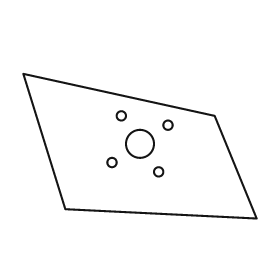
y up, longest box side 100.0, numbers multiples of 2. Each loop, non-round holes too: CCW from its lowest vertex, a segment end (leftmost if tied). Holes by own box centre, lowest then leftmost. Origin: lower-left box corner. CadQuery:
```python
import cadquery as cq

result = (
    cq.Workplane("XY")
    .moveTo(100.0, 0.0)
    .lineTo(82.0, 44.0)
    .lineTo(0.0, 62.0)
    .lineTo(18.0, 4.0)
    .close()
    .moveTo(58.0, 20.0)
    .circle(2.0)
    .moveTo(38.0, 24.0)
    .circle(2.0)
    .moveTo(50.0, 32.0)
    .circle(6.0)
    .moveTo(62.0, 40.0)
    .circle(2.0)
    .moveTo(42.0, 44.0)
    .circle(2.0)
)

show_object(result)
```